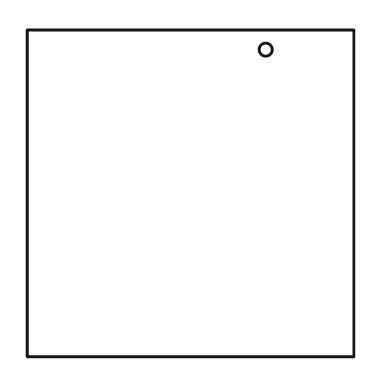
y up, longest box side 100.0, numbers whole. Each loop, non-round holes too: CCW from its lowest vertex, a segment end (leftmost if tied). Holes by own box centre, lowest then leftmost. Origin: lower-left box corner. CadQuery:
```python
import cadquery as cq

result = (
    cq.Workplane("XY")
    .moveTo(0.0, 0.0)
    .lineTo(100.0, 0.0)
    .lineTo(100.0, 100.0)
    .lineTo(0.0, 100.0)
    .close()
    .moveTo(73.0, 94.0)
    .circle(2.0)
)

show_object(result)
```